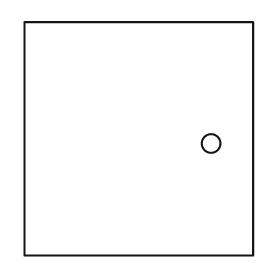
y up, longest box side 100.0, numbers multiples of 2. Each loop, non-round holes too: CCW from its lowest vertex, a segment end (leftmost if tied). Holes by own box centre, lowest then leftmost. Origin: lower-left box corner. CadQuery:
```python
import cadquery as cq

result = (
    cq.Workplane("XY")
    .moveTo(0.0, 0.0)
    .lineTo(98.0, 0.0)
    .lineTo(98.0, 100.0)
    .lineTo(0.0, 100.0)
    .close()
    .moveTo(80.0, 48.0)
    .circle(4.0)
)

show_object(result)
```